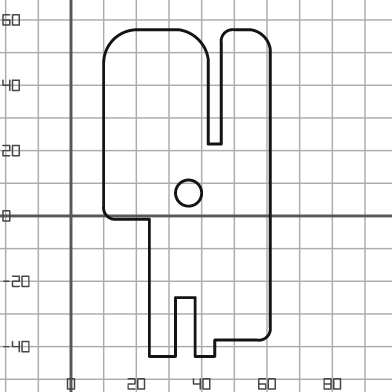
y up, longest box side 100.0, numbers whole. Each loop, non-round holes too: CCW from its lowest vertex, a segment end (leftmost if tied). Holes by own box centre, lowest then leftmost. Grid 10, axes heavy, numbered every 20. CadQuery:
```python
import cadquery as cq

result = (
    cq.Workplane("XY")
    .moveTo(24.0, -43.0)
    .lineTo(32.0, -43.0)
    .lineTo(32.0, -25.0)
    .lineTo(38.0, -25.0)
    .lineTo(38.0, -43.0)
    .lineTo(44.0, -43.0)
    .lineTo(44.0, -38.0)
    .lineTo(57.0, -38.0)
    .threePointArc((60.0, -37.0), (61.0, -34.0))
    .lineTo(61.0, 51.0)
    .threePointArc((59.0, 55.0), (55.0, 57.0))
    .lineTo(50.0, 57.0)
    .threePointArc((47.0, 56.0), (46.0, 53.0))
    .lineTo(46.0, 22.0)
    .lineTo(42.0, 22.0)
    .lineTo(42.0, 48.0)
    .threePointArc((39.0, 54.0), (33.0, 57.0))
    .lineTo(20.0, 57.0)
    .threePointArc((13.0, 54.0), (10.0, 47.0))
    .lineTo(10.0, 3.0)
    .threePointArc((11.0, 0.0), (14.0, -1.0))
    .lineTo(24.0, -1.0)
    .close()
    .moveTo(36.0, 7.0)
    .circle(4.0)
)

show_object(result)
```